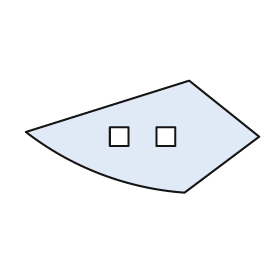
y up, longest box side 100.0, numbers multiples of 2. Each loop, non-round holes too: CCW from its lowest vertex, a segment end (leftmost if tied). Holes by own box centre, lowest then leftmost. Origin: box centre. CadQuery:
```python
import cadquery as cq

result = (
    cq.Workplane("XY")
    .moveTo(18.0, -24.0)
    .lineTo(50.0, 0.0)
    .lineTo(20.0, 24.0)
    .lineTo(-50.0, 2.0)
    .threePointArc((-18.0, -16.0), (18.0, -24.0))
    .close()
    .moveTo(-14.0, -4.0)
    .lineTo(-6.0, -4.0)
    .lineTo(-6.0, 4.0)
    .lineTo(-14.0, 4.0)
    .close()
    .moveTo(6.0, -4.0)
    .lineTo(14.0, -4.0)
    .lineTo(14.0, 4.0)
    .lineTo(6.0, 4.0)
    .close()
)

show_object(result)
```